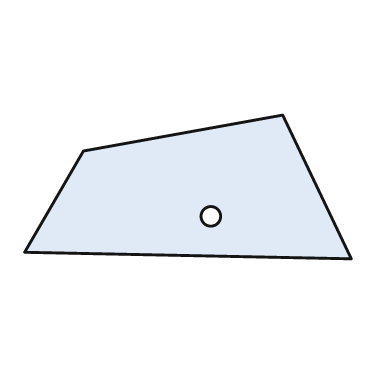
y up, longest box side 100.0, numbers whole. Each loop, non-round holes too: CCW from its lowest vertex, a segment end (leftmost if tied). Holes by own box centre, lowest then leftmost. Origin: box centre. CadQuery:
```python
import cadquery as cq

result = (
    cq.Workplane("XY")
    .moveTo(50.0, -22.0)
    .lineTo(29.0, 22.0)
    .lineTo(-32.0, 11.0)
    .lineTo(-50.0, -20.0)
    .close()
    .moveTo(7.0, -9.0)
    .circle(3.0)
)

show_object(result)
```